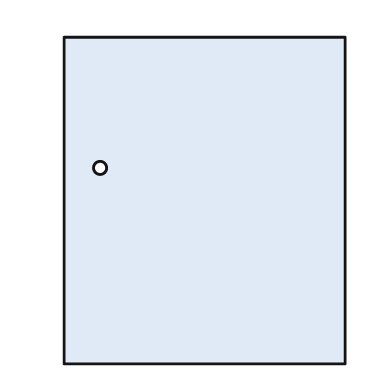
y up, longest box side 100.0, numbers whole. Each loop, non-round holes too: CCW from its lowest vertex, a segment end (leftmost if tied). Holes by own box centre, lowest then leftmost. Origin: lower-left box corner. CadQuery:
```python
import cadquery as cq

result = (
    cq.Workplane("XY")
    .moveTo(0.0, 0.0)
    .lineTo(86.0, 0.0)
    .lineTo(86.0, 100.0)
    .lineTo(0.0, 100.0)
    .close()
    .moveTo(11.0, 60.0)
    .circle(2.0)
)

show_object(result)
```